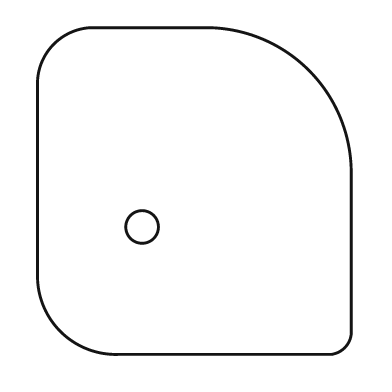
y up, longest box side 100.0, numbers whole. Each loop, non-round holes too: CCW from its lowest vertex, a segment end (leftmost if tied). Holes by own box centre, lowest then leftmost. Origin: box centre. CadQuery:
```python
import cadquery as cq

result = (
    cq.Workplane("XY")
    .moveTo(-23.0, -50.0)
    .lineTo(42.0, -50.0)
    .threePointArc((46.0, -48.0), (48.0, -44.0))
    .lineTo(48.0, 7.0)
    .threePointArc((35.0, 37.0), (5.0, 50.0))
    .lineTo(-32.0, 50.0)
    .threePointArc((-43.0, 45.0), (-48.0, 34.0))
    .lineTo(-48.0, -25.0)
    .threePointArc((-41.0, -43.0), (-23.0, -50.0))
    .close()
    .moveTo(-16.0, -11.0)
    .circle(5.0)
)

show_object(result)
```